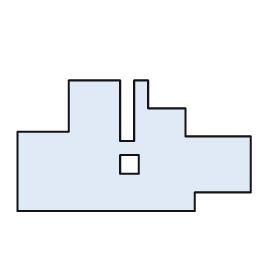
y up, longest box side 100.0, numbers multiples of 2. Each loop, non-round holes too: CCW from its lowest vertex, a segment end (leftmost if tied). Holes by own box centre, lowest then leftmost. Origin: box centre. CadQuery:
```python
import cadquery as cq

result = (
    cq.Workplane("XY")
    .moveTo(-50.0, -28.0)
    .lineTo(26.0, -28.0)
    .lineTo(26.0, -20.0)
    .lineTo(50.0, -20.0)
    .lineTo(50.0, 4.0)
    .lineTo(22.0, 4.0)
    .lineTo(22.0, 16.0)
    .lineTo(6.0, 16.0)
    .lineTo(6.0, 28.0)
    .lineTo(0.0, 28.0)
    .lineTo(0.0, 2.0)
    .lineTo(-6.0, 2.0)
    .lineTo(-6.0, 28.0)
    .lineTo(-28.0, 28.0)
    .lineTo(-28.0, 6.0)
    .lineTo(-50.0, 6.0)
    .close()
    .moveTo(-6.0, -12.0)
    .lineTo(2.0, -12.0)
    .lineTo(2.0, -4.0)
    .lineTo(-6.0, -4.0)
    .close()
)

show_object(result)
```